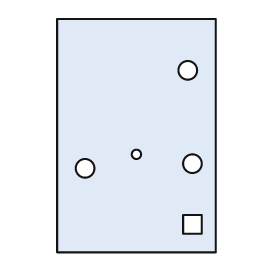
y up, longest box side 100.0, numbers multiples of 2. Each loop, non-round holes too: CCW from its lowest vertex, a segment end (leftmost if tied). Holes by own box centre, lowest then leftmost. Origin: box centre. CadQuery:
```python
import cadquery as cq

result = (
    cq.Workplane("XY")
    .moveTo(-34.0, -50.0)
    .lineTo(34.0, -50.0)
    .lineTo(34.0, 50.0)
    .lineTo(-34.0, 50.0)
    .close()
    .moveTo(20.0, -42.0)
    .lineTo(28.0, -42.0)
    .lineTo(28.0, -34.0)
    .lineTo(20.0, -34.0)
    .close()
    .moveTo(-22.0, -14.0)
    .circle(4.0)
    .moveTo(24.0, -12.0)
    .circle(4.0)
    .moveTo(0.0, -8.0)
    .circle(2.0)
    .moveTo(22.0, 28.0)
    .circle(4.0)
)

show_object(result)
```